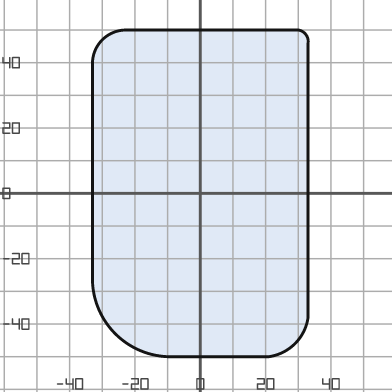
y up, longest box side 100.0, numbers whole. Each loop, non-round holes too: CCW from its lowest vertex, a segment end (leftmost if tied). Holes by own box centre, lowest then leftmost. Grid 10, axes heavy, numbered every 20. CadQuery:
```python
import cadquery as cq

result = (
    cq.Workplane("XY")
    .moveTo(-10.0, -50.0)
    .lineTo(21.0, -50.0)
    .threePointArc((29.0, -46.0), (33.0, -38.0))
    .lineTo(33.0, 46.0)
    .threePointArc((32.0, 49.0), (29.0, 50.0))
    .lineTo(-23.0, 50.0)
    .threePointArc((-30.0, 47.0), (-33.0, 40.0))
    .lineTo(-33.0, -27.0)
    .threePointArc((-26.0, -43.0), (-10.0, -50.0))
    .close()
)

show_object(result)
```